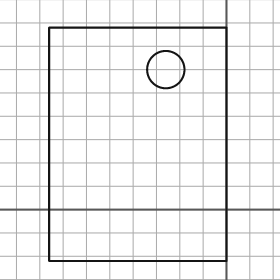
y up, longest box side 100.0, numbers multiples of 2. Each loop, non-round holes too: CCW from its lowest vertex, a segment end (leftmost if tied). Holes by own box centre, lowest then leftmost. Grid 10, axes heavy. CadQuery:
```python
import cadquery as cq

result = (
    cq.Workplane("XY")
    .moveTo(-76.0, -22.0)
    .lineTo(0.0, -22.0)
    .lineTo(0.0, 78.0)
    .lineTo(-76.0, 78.0)
    .close()
    .moveTo(-26.0, 60.0)
    .circle(8.0)
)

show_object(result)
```